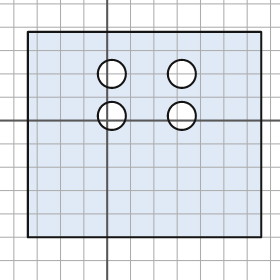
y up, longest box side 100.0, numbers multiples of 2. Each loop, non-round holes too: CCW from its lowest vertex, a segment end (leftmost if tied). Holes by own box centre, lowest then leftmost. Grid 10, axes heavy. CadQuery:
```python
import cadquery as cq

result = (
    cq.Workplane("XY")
    .moveTo(-34.0, -50.0)
    .lineTo(66.0, -50.0)
    .lineTo(66.0, 38.0)
    .lineTo(-34.0, 38.0)
    .close()
    .moveTo(2.0, 2.0)
    .circle(6.0)
    .moveTo(32.0, 2.0)
    .circle(6.0)
    .moveTo(2.0, 20.0)
    .circle(6.0)
    .moveTo(32.0, 20.0)
    .circle(6.0)
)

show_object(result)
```